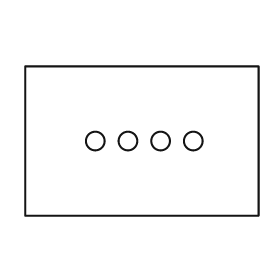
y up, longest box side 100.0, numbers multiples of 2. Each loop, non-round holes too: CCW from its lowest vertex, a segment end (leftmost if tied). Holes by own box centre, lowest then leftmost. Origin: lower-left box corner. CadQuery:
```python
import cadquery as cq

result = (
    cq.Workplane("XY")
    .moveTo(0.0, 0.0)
    .lineTo(100.0, 0.0)
    .lineTo(100.0, 64.0)
    .lineTo(0.0, 64.0)
    .close()
    .moveTo(30.0, 32.0)
    .circle(4.0)
    .moveTo(44.0, 32.0)
    .circle(4.0)
    .moveTo(58.0, 32.0)
    .circle(4.0)
    .moveTo(72.0, 32.0)
    .circle(4.0)
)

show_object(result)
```